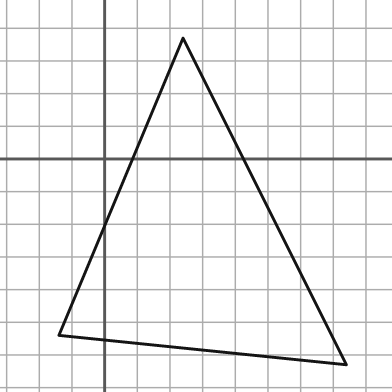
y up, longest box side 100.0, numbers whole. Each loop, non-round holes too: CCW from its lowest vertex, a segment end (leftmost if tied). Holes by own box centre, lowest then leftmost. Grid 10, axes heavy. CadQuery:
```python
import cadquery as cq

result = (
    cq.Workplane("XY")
    .moveTo(74.0, -63.0)
    .lineTo(24.0, 37.0)
    .lineTo(-14.0, -54.0)
    .close()
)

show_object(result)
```